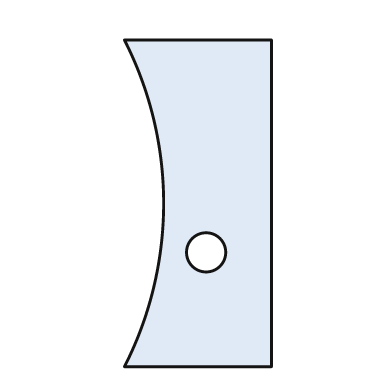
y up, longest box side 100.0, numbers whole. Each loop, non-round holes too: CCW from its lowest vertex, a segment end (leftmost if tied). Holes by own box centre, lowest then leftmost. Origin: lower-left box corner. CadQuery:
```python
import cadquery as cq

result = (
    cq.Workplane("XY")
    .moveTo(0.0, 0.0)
    .lineTo(45.0, 0.0)
    .lineTo(45.0, 100.0)
    .lineTo(0.0, 100.0)
    .threePointArc((12.0, 50.0), (0.0, 0.0))
    .close()
    .moveTo(25.0, 35.0)
    .circle(6.0)
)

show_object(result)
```